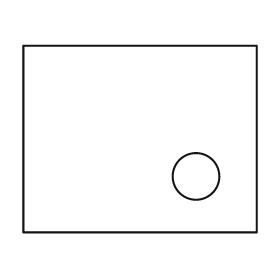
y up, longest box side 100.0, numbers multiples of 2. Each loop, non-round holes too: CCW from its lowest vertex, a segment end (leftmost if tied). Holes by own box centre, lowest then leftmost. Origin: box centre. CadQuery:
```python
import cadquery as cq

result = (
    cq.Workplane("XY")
    .moveTo(-50.0, -40.0)
    .lineTo(50.0, -40.0)
    .lineTo(50.0, 40.0)
    .lineTo(-50.0, 40.0)
    .close()
    .moveTo(24.0, -16.0)
    .circle(10.0)
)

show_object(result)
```